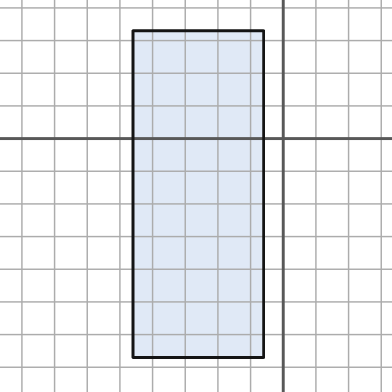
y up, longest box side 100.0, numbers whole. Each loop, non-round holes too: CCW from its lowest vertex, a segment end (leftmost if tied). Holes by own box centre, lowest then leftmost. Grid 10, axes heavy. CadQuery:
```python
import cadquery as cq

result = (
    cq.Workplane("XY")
    .moveTo(-46.0, -67.0)
    .lineTo(-6.0, -67.0)
    .lineTo(-6.0, 33.0)
    .lineTo(-46.0, 33.0)
    .close()
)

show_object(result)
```